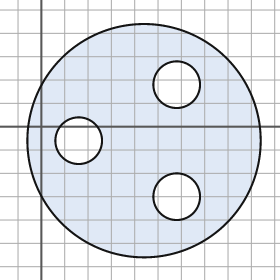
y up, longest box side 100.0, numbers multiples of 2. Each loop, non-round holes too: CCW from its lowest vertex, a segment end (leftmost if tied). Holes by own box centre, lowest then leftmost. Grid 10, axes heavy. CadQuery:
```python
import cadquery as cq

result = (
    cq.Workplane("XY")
    .moveTo(44.0, -6.0)
    .circle(50.0)
    .moveTo(58.0, -30.0)
    .circle(10.0)
    .moveTo(16.0, -6.0)
    .circle(10.0)
    .moveTo(58.0, 18.0)
    .circle(10.0)
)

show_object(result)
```